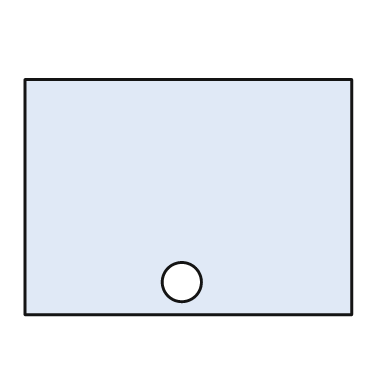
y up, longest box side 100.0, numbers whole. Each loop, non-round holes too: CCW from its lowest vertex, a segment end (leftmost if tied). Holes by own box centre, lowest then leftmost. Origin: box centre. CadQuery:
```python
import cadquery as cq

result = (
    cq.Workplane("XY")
    .moveTo(-50.0, -36.0)
    .lineTo(50.0, -36.0)
    .lineTo(50.0, 36.0)
    .lineTo(-50.0, 36.0)
    .close()
    .moveTo(-2.0, -26.0)
    .circle(6.0)
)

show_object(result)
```